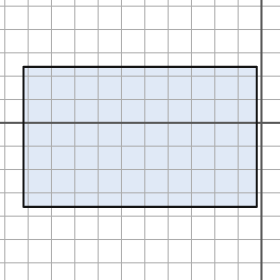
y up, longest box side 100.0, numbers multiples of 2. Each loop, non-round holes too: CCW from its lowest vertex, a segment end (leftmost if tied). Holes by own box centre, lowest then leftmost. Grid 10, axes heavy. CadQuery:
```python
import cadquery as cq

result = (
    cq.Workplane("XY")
    .moveTo(-102.0, -36.0)
    .lineTo(-2.0, -36.0)
    .lineTo(-2.0, 24.0)
    .lineTo(-102.0, 24.0)
    .close()
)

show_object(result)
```